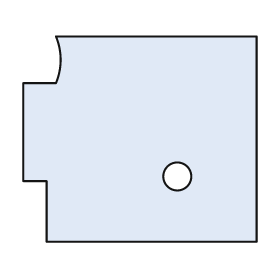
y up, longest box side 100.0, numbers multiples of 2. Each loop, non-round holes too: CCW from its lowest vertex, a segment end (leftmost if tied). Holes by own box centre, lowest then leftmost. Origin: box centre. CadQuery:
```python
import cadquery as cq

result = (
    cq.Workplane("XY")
    .moveTo(-40.0, -44.0)
    .lineTo(50.0, -44.0)
    .lineTo(50.0, 44.0)
    .lineTo(-36.0, 44.0)
    .threePointArc((-34.0, 34.0), (-36.0, 24.0))
    .lineTo(-50.0, 24.0)
    .lineTo(-50.0, -18.0)
    .lineTo(-40.0, -18.0)
    .close()
    .moveTo(16.0, -16.0)
    .circle(6.0)
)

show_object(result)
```